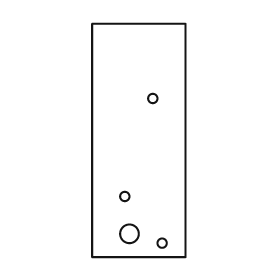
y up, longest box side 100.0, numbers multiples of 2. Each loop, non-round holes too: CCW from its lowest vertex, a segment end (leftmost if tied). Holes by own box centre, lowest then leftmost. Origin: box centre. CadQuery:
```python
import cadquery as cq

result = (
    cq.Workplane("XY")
    .moveTo(-20.0, -50.0)
    .lineTo(20.0, -50.0)
    .lineTo(20.0, 50.0)
    .lineTo(-20.0, 50.0)
    .close()
    .moveTo(10.0, -44.0)
    .circle(2.0)
    .moveTo(-4.0, -40.0)
    .circle(4.0)
    .moveTo(-6.0, -24.0)
    .circle(2.0)
    .moveTo(6.0, 18.0)
    .circle(2.0)
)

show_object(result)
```